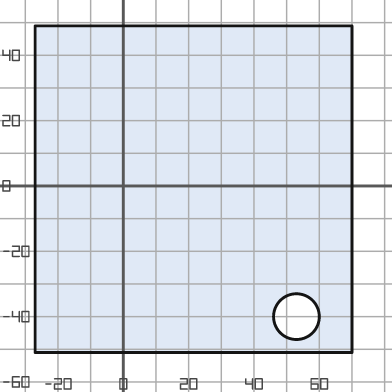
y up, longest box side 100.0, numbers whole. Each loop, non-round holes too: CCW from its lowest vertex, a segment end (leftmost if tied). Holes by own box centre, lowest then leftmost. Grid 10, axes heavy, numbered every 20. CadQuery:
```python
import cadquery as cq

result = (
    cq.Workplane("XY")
    .moveTo(-27.0, -51.0)
    .lineTo(70.0, -51.0)
    .lineTo(70.0, 49.0)
    .lineTo(-27.0, 49.0)
    .close()
    .moveTo(53.0, -40.0)
    .circle(7.0)
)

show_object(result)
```